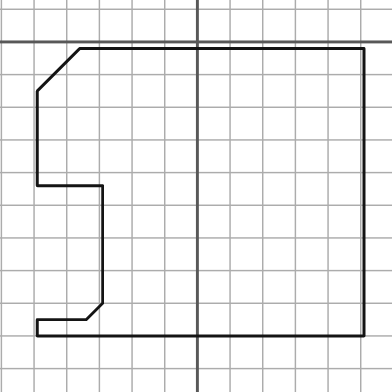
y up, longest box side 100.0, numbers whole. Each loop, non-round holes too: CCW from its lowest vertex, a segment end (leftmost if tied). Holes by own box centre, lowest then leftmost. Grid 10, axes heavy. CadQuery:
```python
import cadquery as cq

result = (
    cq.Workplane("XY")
    .moveTo(-49.0, -90.0)
    .lineTo(51.0, -90.0)
    .lineTo(51.0, -2.0)
    .lineTo(-36.0, -2.0)
    .lineTo(-49.0, -15.0)
    .lineTo(-49.0, -44.0)
    .lineTo(-29.0, -44.0)
    .lineTo(-29.0, -80.0)
    .lineTo(-34.0, -85.0)
    .lineTo(-49.0, -85.0)
    .close()
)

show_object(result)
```